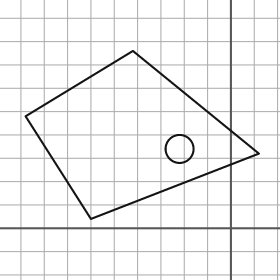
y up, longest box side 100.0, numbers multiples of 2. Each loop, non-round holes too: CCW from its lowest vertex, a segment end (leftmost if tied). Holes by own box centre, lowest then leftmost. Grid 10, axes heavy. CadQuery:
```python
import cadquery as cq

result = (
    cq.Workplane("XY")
    .moveTo(-60.0, 4.0)
    .lineTo(12.0, 32.0)
    .lineTo(-42.0, 76.0)
    .lineTo(-88.0, 48.0)
    .close()
    .moveTo(-22.0, 34.0)
    .circle(6.0)
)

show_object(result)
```